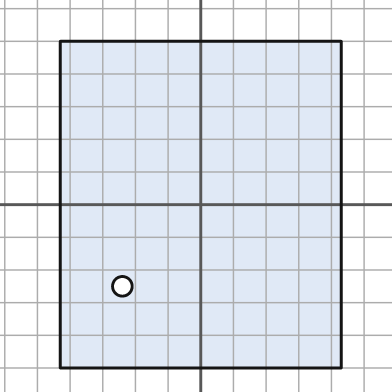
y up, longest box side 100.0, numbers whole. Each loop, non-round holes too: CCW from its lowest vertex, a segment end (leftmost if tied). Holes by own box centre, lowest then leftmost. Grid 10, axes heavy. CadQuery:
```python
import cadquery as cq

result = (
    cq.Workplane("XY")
    .moveTo(-43.0, -50.0)
    .lineTo(43.0, -50.0)
    .lineTo(43.0, 50.0)
    .lineTo(-43.0, 50.0)
    .close()
    .moveTo(-24.0, -25.0)
    .circle(3.0)
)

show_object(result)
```